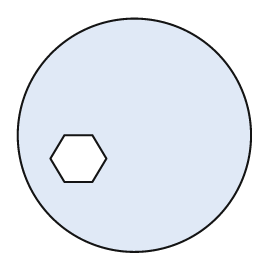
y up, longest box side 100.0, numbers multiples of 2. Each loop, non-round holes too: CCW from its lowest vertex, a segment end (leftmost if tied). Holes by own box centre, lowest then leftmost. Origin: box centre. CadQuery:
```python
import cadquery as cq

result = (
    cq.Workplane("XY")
    .moveTo(0.0, 0.0)
    .circle(50.0)
    .moveTo(-30.0, -20.0)
    .lineTo(-18.0, -20.0)
    .lineTo(-12.0, -10.0)
    .lineTo(-18.0, 0.0)
    .lineTo(-30.0, 0.0)
    .lineTo(-36.0, -10.0)
    .close()
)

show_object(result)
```